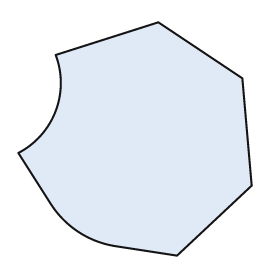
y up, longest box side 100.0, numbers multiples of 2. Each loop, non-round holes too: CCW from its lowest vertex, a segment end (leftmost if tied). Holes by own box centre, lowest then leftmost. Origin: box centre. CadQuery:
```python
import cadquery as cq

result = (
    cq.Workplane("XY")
    .moveTo(18.0, -50.0)
    .lineTo(50.0, -20.0)
    .lineTo(46.0, 26.0)
    .lineTo(10.0, 50.0)
    .lineTo(-34.0, 36.0)
    .threePointArc((-34.0, 12.0), (-50.0, -6.0))
    .lineTo(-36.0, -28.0)
    .threePointArc((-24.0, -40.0), (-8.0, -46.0))
    .close()
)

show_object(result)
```